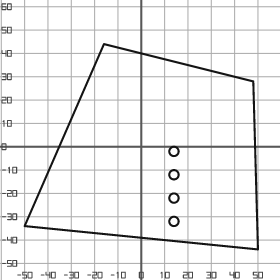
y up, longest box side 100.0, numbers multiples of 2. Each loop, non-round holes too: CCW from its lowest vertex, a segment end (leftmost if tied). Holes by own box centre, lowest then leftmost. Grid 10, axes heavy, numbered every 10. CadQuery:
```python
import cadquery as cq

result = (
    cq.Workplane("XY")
    .moveTo(50.0, -44.0)
    .lineTo(48.0, 28.0)
    .lineTo(-16.0, 44.0)
    .lineTo(-50.0, -34.0)
    .close()
    .moveTo(14.0, -32.0)
    .circle(2.0)
    .moveTo(14.0, -22.0)
    .circle(2.0)
    .moveTo(14.0, -12.0)
    .circle(2.0)
    .moveTo(14.0, -2.0)
    .circle(2.0)
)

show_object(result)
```